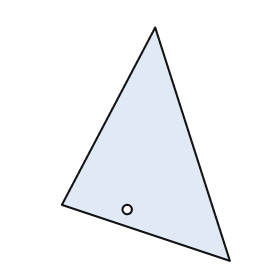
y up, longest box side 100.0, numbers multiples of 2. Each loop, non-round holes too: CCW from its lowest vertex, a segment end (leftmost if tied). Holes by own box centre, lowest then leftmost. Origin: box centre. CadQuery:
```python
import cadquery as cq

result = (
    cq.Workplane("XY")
    .moveTo(36.0, -50.0)
    .lineTo(4.0, 50.0)
    .lineTo(-36.0, -26.0)
    .close()
    .moveTo(-8.0, -28.0)
    .circle(2.0)
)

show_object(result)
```